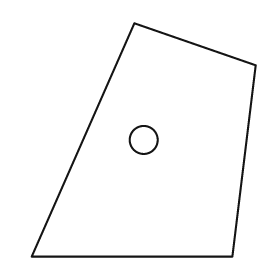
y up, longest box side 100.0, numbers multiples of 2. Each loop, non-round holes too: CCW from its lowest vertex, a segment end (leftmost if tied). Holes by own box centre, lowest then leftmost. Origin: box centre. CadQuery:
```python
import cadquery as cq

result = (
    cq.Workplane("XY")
    .moveTo(-48.0, -50.0)
    .lineTo(38.0, -50.0)
    .lineTo(48.0, 32.0)
    .lineTo(-4.0, 50.0)
    .close()
    .moveTo(0.0, 0.0)
    .circle(6.0)
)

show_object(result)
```